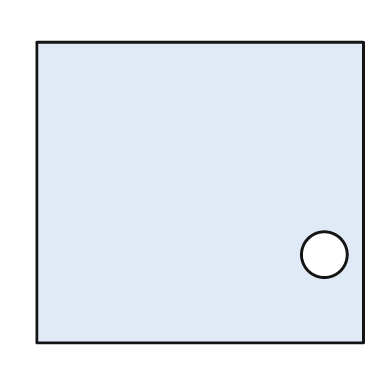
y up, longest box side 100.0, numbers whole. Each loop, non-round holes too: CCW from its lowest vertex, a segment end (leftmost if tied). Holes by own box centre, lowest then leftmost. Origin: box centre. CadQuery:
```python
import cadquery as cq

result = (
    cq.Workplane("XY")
    .moveTo(-50.0, -46.0)
    .lineTo(50.0, -46.0)
    .lineTo(50.0, 46.0)
    .lineTo(-50.0, 46.0)
    .close()
    .moveTo(38.0, -19.0)
    .circle(7.0)
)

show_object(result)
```